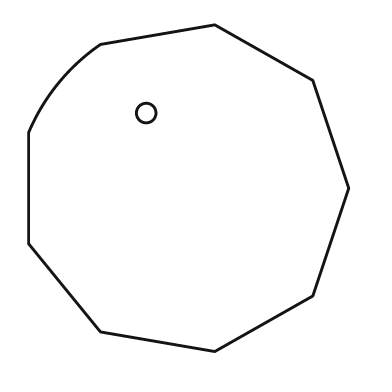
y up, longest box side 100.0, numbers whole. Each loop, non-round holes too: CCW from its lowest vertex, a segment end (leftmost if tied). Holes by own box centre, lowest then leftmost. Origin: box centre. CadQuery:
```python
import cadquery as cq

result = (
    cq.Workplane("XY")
    .moveTo(8.0, -50.0)
    .lineTo(38.0, -33.0)
    .lineTo(49.0, 0.0)
    .lineTo(38.0, 33.0)
    .lineTo(8.0, 50.0)
    .lineTo(-27.0, 44.0)
    .threePointArc((-40.0, 32.0), (-49.0, 17.0))
    .lineTo(-49.0, -17.0)
    .lineTo(-27.0, -44.0)
    .close()
    .moveTo(-13.0, 23.0)
    .circle(3.0)
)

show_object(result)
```